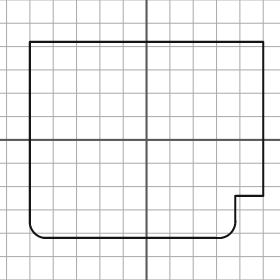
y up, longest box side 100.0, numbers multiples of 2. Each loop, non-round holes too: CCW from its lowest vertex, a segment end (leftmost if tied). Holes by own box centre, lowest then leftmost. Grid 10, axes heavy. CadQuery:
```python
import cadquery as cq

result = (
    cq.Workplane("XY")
    .moveTo(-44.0, -42.0)
    .lineTo(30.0, -42.0)
    .threePointArc((36.0, -40.0), (38.0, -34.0))
    .lineTo(38.0, -24.0)
    .lineTo(50.0, -24.0)
    .lineTo(50.0, 42.0)
    .lineTo(-50.0, 42.0)
    .lineTo(-50.0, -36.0)
    .threePointArc((-48.0, -40.0), (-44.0, -42.0))
    .close()
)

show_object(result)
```